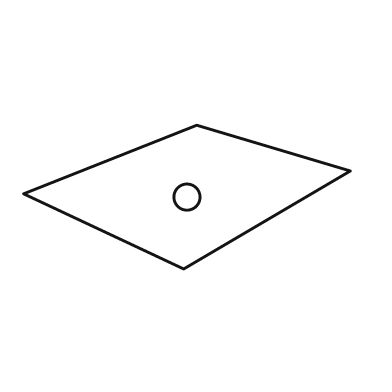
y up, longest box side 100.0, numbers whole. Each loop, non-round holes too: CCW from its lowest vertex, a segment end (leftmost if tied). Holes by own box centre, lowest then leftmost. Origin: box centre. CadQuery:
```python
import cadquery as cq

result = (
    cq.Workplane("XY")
    .moveTo(-1.0, -22.0)
    .lineTo(50.0, 8.0)
    .lineTo(3.0, 22.0)
    .lineTo(-50.0, 1.0)
    .close()
    .moveTo(0.0, 0.0)
    .circle(4.0)
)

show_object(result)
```